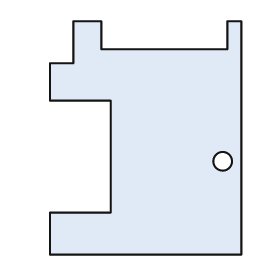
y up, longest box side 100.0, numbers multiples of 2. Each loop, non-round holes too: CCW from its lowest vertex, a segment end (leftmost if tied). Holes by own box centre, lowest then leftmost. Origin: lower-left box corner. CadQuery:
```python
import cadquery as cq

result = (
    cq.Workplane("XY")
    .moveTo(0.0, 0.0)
    .lineTo(82.0, 0.0)
    .lineTo(82.0, 100.0)
    .lineTo(76.0, 100.0)
    .lineTo(76.0, 88.0)
    .lineTo(22.0, 88.0)
    .lineTo(22.0, 100.0)
    .lineTo(10.0, 100.0)
    .lineTo(10.0, 82.0)
    .lineTo(0.0, 82.0)
    .lineTo(0.0, 66.0)
    .lineTo(26.0, 66.0)
    .lineTo(26.0, 18.0)
    .lineTo(0.0, 18.0)
    .close()
    .moveTo(74.0, 40.0)
    .circle(4.0)
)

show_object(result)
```